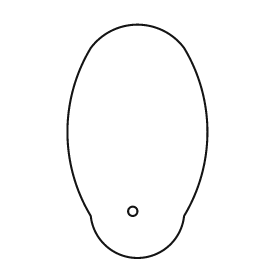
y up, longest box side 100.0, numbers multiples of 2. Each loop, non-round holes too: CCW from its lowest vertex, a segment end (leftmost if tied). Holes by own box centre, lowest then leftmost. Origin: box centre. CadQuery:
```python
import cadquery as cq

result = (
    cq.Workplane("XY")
    .moveTo(-20.0, -32.0)
    .threePointArc((0.0, -50.0), (20.0, -32.0))
    .threePointArc((30.0, 4.0), (20.0, 40.0))
    .threePointArc((0.0, 50.0), (-20.0, 40.0))
    .threePointArc((-30.0, 4.0), (-20.0, -32.0))
    .close()
    .moveTo(-2.0, -30.0)
    .circle(2.0)
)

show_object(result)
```